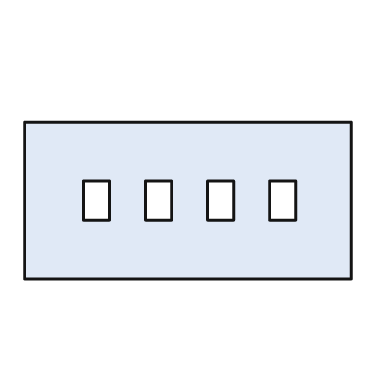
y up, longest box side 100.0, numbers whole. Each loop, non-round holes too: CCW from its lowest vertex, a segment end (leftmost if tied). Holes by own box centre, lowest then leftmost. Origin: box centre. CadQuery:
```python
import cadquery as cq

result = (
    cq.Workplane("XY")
    .moveTo(-50.0, -24.0)
    .lineTo(50.0, -24.0)
    .lineTo(50.0, 24.0)
    .lineTo(-50.0, 24.0)
    .close()
    .moveTo(-32.0, -6.0)
    .lineTo(-24.0, -6.0)
    .lineTo(-24.0, 6.0)
    .lineTo(-32.0, 6.0)
    .close()
    .moveTo(-13.0, -6.0)
    .lineTo(-5.0, -6.0)
    .lineTo(-5.0, 6.0)
    .lineTo(-13.0, 6.0)
    .close()
    .moveTo(6.0, -6.0)
    .lineTo(14.0, -6.0)
    .lineTo(14.0, 6.0)
    .lineTo(6.0, 6.0)
    .close()
    .moveTo(25.0, -6.0)
    .lineTo(33.0, -6.0)
    .lineTo(33.0, 6.0)
    .lineTo(25.0, 6.0)
    .close()
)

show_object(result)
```